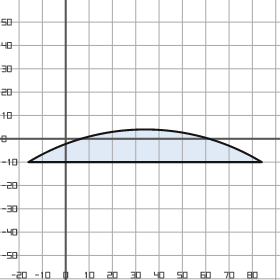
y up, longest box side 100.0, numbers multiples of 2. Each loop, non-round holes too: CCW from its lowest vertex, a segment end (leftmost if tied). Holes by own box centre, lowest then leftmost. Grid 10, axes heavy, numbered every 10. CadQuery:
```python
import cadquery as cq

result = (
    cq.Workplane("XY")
    .moveTo(-16.0, -10.0)
    .lineTo(84.0, -10.0)
    .threePointArc((34.0, 4.0), (-16.0, -10.0))
    .close()
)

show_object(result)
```